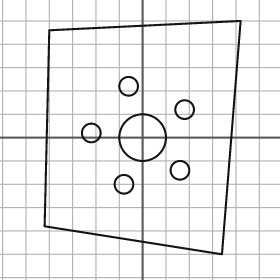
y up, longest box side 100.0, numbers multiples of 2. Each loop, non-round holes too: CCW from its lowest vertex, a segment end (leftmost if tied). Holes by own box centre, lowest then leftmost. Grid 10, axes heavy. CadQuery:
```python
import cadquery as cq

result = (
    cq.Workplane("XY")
    .moveTo(34.0, -50.0)
    .lineTo(42.0, 50.0)
    .lineTo(-40.0, 46.0)
    .lineTo(-42.0, -38.0)
    .close()
    .moveTo(-8.0, -20.0)
    .circle(4.0)
    .moveTo(16.0, -14.0)
    .circle(4.0)
    .moveTo(0.0, 0.0)
    .circle(10.0)
    .moveTo(-22.0, 2.0)
    .circle(4.0)
    .moveTo(18.0, 12.0)
    .circle(4.0)
    .moveTo(-6.0, 22.0)
    .circle(4.0)
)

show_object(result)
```